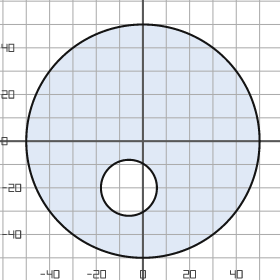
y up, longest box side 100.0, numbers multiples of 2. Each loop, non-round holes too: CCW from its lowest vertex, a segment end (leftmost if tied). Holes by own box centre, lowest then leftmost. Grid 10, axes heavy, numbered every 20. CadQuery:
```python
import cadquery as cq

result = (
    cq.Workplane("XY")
    .moveTo(0.0, 0.0)
    .circle(50.0)
    .moveTo(-6.0, -20.0)
    .circle(12.0)
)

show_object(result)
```